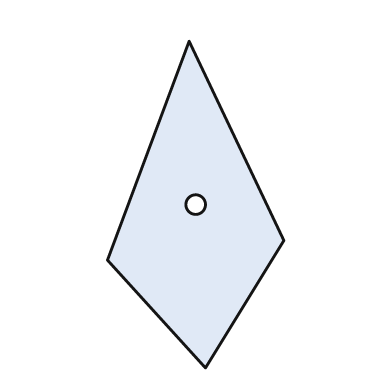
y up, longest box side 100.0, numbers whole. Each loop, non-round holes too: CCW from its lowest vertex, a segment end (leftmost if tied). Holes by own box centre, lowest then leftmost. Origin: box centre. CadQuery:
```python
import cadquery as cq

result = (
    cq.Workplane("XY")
    .moveTo(3.0, -50.0)
    .lineTo(27.0, -11.0)
    .lineTo(-2.0, 50.0)
    .lineTo(-27.0, -17.0)
    .close()
    .moveTo(0.0, 0.0)
    .circle(3.0)
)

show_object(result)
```